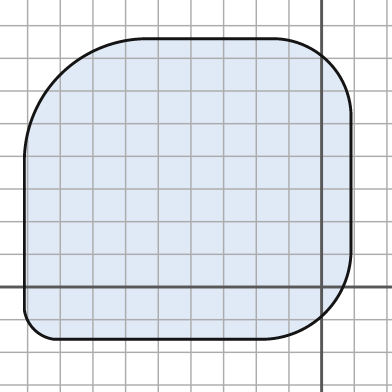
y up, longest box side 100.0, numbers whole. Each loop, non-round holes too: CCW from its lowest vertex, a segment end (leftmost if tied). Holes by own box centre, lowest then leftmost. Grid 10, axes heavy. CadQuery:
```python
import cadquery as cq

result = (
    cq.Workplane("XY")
    .moveTo(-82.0, -16.0)
    .lineTo(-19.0, -16.0)
    .threePointArc((1.0, -8.0), (9.0, 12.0))
    .lineTo(9.0, 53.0)
    .threePointArc((2.0, 69.0), (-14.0, 76.0))
    .lineTo(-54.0, 76.0)
    .threePointArc((-80.0, 65.0), (-91.0, 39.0))
    .lineTo(-91.0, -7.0)
    .threePointArc((-88.0, -13.0), (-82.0, -16.0))
    .close()
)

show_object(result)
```